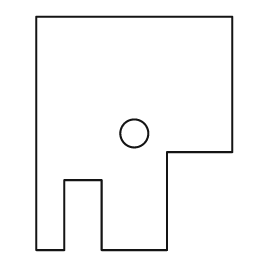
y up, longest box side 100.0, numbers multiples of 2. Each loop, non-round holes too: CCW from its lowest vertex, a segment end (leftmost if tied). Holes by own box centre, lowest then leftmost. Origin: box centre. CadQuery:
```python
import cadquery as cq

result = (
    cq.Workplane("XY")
    .moveTo(-42.0, -50.0)
    .lineTo(-30.0, -50.0)
    .lineTo(-30.0, -20.0)
    .lineTo(-14.0, -20.0)
    .lineTo(-14.0, -50.0)
    .lineTo(14.0, -50.0)
    .lineTo(14.0, -8.0)
    .lineTo(42.0, -8.0)
    .lineTo(42.0, 50.0)
    .lineTo(-42.0, 50.0)
    .close()
    .moveTo(0.0, 0.0)
    .circle(6.0)
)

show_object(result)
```